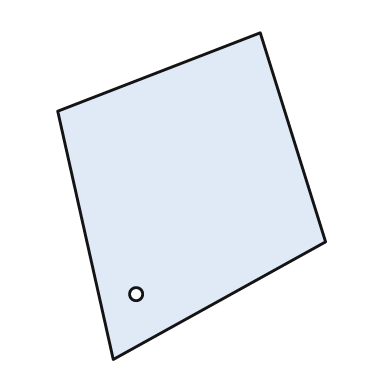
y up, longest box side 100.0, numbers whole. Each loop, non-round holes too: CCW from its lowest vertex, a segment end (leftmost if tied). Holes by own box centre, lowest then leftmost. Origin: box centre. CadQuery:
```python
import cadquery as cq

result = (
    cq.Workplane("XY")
    .moveTo(-24.0, -50.0)
    .lineTo(41.0, -14.0)
    .lineTo(21.0, 50.0)
    .lineTo(-41.0, 26.0)
    .close()
    .moveTo(-17.0, -30.0)
    .circle(2.0)
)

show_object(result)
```